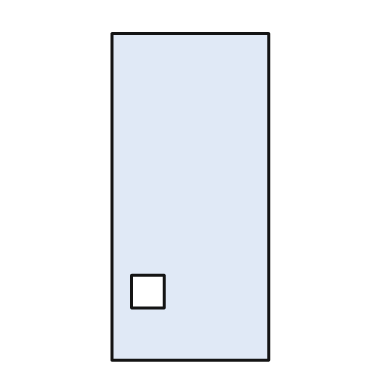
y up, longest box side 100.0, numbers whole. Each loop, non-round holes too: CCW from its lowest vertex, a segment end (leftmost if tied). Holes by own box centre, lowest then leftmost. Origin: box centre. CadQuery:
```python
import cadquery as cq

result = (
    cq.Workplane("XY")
    .moveTo(-24.0, -50.0)
    .lineTo(24.0, -50.0)
    .lineTo(24.0, 50.0)
    .lineTo(-24.0, 50.0)
    .close()
    .moveTo(-18.0, -34.0)
    .lineTo(-8.0, -34.0)
    .lineTo(-8.0, -24.0)
    .lineTo(-18.0, -24.0)
    .close()
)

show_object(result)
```